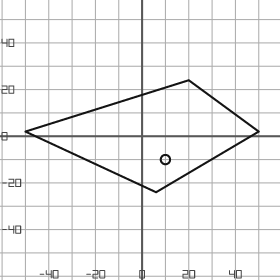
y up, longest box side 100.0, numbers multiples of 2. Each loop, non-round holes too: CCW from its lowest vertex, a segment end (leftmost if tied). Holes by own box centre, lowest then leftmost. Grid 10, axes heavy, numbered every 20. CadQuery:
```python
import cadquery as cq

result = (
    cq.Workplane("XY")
    .moveTo(6.0, -24.0)
    .lineTo(50.0, 2.0)
    .lineTo(20.0, 24.0)
    .lineTo(-50.0, 2.0)
    .close()
    .moveTo(10.0, -10.0)
    .circle(2.0)
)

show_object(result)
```